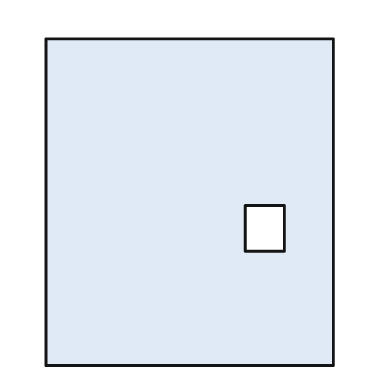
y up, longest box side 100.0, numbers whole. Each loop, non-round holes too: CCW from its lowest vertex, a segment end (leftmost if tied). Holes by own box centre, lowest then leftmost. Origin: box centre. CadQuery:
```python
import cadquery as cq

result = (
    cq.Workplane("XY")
    .moveTo(-44.0, -50.0)
    .lineTo(44.0, -50.0)
    .lineTo(44.0, 50.0)
    .lineTo(-44.0, 50.0)
    .close()
    .moveTo(17.0, -15.0)
    .lineTo(29.0, -15.0)
    .lineTo(29.0, -1.0)
    .lineTo(17.0, -1.0)
    .close()
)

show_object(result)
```